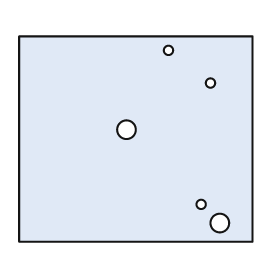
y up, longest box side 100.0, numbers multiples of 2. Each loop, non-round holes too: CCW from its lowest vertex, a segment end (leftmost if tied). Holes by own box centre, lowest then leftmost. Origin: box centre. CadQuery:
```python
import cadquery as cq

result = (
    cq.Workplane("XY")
    .moveTo(-50.0, -44.0)
    .lineTo(50.0, -44.0)
    .lineTo(50.0, 44.0)
    .lineTo(-50.0, 44.0)
    .close()
    .moveTo(36.0, -36.0)
    .circle(4.0)
    .moveTo(28.0, -28.0)
    .circle(2.0)
    .moveTo(-4.0, 4.0)
    .circle(4.0)
    .moveTo(32.0, 24.0)
    .circle(2.0)
    .moveTo(14.0, 38.0)
    .circle(2.0)
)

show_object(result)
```